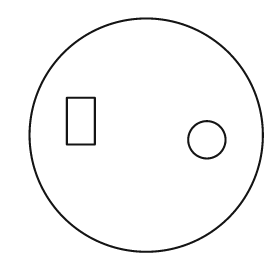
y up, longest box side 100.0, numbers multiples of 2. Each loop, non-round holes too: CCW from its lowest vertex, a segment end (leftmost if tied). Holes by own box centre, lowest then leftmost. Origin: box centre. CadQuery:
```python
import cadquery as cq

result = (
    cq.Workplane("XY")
    .moveTo(0.0, 0.0)
    .circle(50.0)
    .moveTo(26.0, -2.0)
    .circle(8.0)
    .moveTo(-34.0, -4.0)
    .lineTo(-22.0, -4.0)
    .lineTo(-22.0, 16.0)
    .lineTo(-34.0, 16.0)
    .close()
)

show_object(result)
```